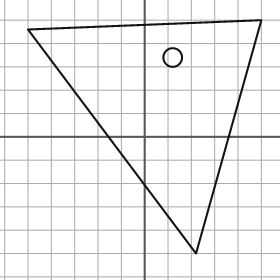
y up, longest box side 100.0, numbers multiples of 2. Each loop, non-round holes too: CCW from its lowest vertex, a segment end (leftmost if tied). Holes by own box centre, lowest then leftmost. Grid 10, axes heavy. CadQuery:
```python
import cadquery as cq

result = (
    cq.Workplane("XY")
    .moveTo(22.0, -50.0)
    .lineTo(50.0, 50.0)
    .lineTo(-50.0, 46.0)
    .close()
    .moveTo(12.0, 34.0)
    .circle(4.0)
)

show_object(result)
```